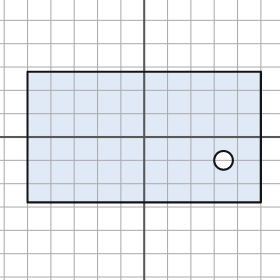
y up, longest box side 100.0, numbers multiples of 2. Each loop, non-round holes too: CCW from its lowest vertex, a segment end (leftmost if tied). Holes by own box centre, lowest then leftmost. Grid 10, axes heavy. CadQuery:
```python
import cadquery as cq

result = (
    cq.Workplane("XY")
    .moveTo(-50.0, -28.0)
    .lineTo(50.0, -28.0)
    .lineTo(50.0, 28.0)
    .lineTo(-50.0, 28.0)
    .close()
    .moveTo(34.0, -10.0)
    .circle(4.0)
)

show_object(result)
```